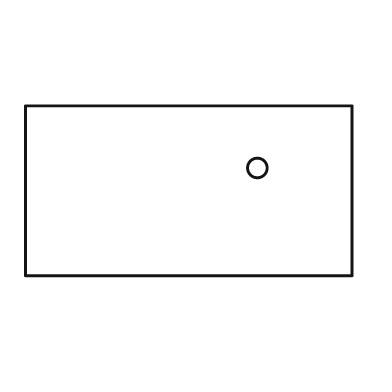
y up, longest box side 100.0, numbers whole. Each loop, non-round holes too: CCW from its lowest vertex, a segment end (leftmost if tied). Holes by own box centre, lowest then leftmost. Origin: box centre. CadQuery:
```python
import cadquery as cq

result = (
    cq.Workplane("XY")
    .moveTo(-50.0, -26.0)
    .lineTo(50.0, -26.0)
    .lineTo(50.0, 26.0)
    .lineTo(-50.0, 26.0)
    .close()
    .moveTo(21.0, 7.0)
    .circle(3.0)
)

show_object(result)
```